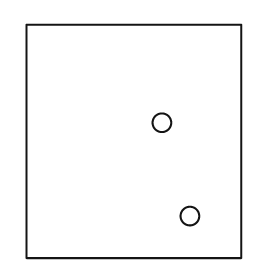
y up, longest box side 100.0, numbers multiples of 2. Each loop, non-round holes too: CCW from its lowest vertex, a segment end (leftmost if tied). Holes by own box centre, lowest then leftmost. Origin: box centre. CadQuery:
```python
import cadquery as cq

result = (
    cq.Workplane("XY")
    .moveTo(-46.0, -50.0)
    .lineTo(46.0, -50.0)
    .lineTo(46.0, 50.0)
    .lineTo(-46.0, 50.0)
    .close()
    .moveTo(24.0, -32.0)
    .circle(4.0)
    .moveTo(12.0, 8.0)
    .circle(4.0)
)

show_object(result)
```